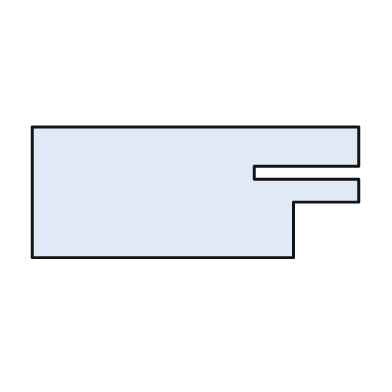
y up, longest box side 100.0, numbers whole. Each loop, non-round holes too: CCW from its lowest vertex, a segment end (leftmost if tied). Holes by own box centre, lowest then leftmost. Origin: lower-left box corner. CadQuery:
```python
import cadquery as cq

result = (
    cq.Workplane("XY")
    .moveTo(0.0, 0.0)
    .lineTo(80.0, 0.0)
    .lineTo(80.0, 17.0)
    .lineTo(100.0, 17.0)
    .lineTo(100.0, 24.0)
    .lineTo(68.0, 24.0)
    .lineTo(68.0, 28.0)
    .lineTo(100.0, 28.0)
    .lineTo(100.0, 40.0)
    .lineTo(0.0, 40.0)
    .close()
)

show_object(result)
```